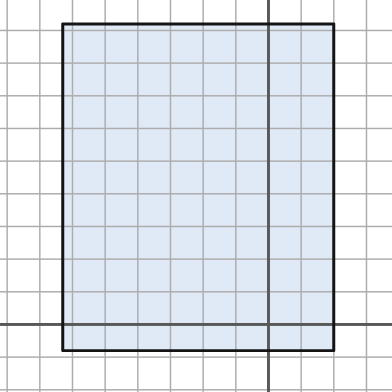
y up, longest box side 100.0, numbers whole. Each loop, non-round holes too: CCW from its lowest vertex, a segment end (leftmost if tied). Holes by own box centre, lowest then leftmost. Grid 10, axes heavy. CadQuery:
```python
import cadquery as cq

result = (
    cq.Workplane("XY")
    .moveTo(-63.0, -8.0)
    .lineTo(20.0, -8.0)
    .lineTo(20.0, 92.0)
    .lineTo(-63.0, 92.0)
    .close()
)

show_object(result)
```